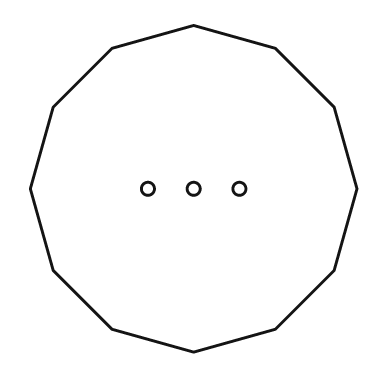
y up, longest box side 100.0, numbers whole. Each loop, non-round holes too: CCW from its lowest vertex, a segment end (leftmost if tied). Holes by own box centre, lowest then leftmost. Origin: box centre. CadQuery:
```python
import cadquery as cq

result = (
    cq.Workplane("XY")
    .moveTo(0.0, -50.0)
    .lineTo(25.0, -43.0)
    .lineTo(43.0, -25.0)
    .lineTo(50.0, 0.0)
    .lineTo(43.0, 25.0)
    .lineTo(25.0, 43.0)
    .lineTo(0.0, 50.0)
    .lineTo(-25.0, 43.0)
    .lineTo(-43.0, 25.0)
    .lineTo(-50.0, 0.0)
    .lineTo(-43.0, -25.0)
    .lineTo(-25.0, -43.0)
    .close()
    .moveTo(-14.0, 0.0)
    .circle(2.0)
    .moveTo(0.0, 0.0)
    .circle(2.0)
    .moveTo(14.0, 0.0)
    .circle(2.0)
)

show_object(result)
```